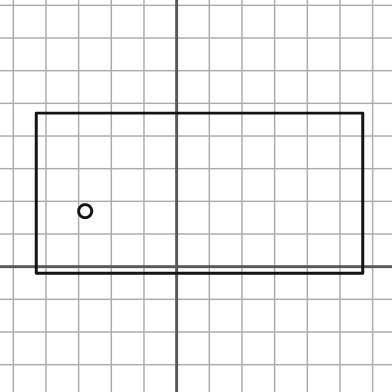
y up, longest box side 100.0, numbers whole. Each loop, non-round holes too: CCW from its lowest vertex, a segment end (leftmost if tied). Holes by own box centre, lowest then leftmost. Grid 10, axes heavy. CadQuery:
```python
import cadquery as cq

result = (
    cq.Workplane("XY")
    .moveTo(-43.0, -2.0)
    .lineTo(57.0, -2.0)
    .lineTo(57.0, 47.0)
    .lineTo(-43.0, 47.0)
    .close()
    .moveTo(-28.0, 17.0)
    .circle(2.0)
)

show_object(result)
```